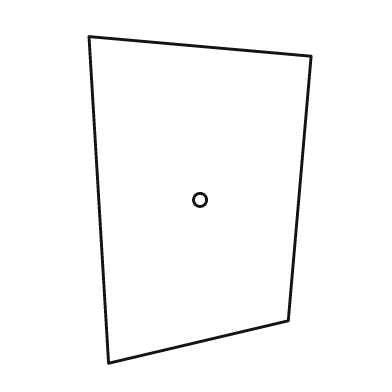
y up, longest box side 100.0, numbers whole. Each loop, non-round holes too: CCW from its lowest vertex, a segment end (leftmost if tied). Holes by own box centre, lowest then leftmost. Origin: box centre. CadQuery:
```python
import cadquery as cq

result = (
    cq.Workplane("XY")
    .moveTo(-28.0, -50.0)
    .lineTo(27.0, -37.0)
    .lineTo(34.0, 44.0)
    .lineTo(-34.0, 50.0)
    .close()
    .moveTo(0.0, 0.0)
    .circle(2.0)
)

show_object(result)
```